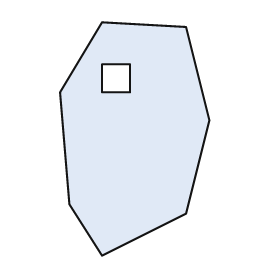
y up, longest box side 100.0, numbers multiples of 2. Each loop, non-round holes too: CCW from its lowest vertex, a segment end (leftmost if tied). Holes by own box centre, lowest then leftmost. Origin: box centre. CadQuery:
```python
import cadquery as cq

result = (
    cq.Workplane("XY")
    .moveTo(-14.0, -50.0)
    .lineTo(22.0, -32.0)
    .lineTo(32.0, 8.0)
    .lineTo(22.0, 48.0)
    .lineTo(-14.0, 50.0)
    .lineTo(-32.0, 20.0)
    .lineTo(-28.0, -28.0)
    .close()
    .moveTo(-14.0, 20.0)
    .lineTo(-2.0, 20.0)
    .lineTo(-2.0, 32.0)
    .lineTo(-14.0, 32.0)
    .close()
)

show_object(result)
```